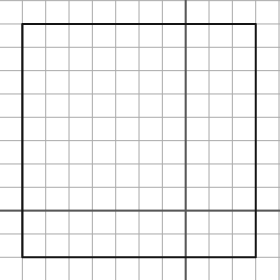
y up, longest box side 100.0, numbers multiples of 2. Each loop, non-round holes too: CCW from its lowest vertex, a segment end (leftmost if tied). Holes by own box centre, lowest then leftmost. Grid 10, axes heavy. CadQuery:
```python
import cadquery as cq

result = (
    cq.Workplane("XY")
    .moveTo(-70.0, -20.0)
    .lineTo(30.0, -20.0)
    .lineTo(30.0, 80.0)
    .lineTo(-70.0, 80.0)
    .close()
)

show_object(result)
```